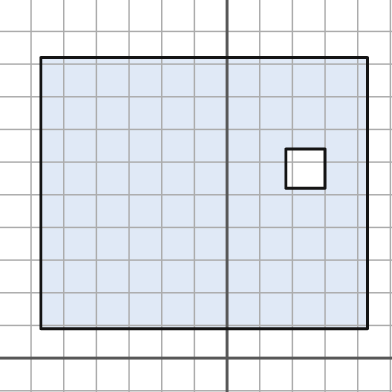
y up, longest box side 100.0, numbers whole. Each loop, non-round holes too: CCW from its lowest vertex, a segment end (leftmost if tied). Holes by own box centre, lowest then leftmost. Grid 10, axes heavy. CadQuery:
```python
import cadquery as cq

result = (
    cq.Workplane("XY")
    .moveTo(-57.0, 9.0)
    .lineTo(43.0, 9.0)
    .lineTo(43.0, 92.0)
    .lineTo(-57.0, 92.0)
    .close()
    .moveTo(18.0, 52.0)
    .lineTo(30.0, 52.0)
    .lineTo(30.0, 64.0)
    .lineTo(18.0, 64.0)
    .close()
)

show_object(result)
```